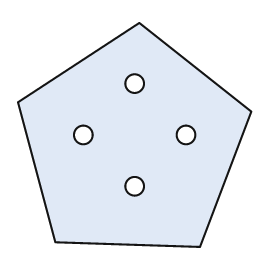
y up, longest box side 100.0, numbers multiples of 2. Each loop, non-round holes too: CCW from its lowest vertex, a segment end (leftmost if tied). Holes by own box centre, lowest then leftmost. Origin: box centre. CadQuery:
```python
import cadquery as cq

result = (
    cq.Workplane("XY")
    .moveTo(28.0, -48.0)
    .lineTo(50.0, 10.0)
    .lineTo(2.0, 48.0)
    .lineTo(-50.0, 14.0)
    .lineTo(-34.0, -46.0)
    .close()
    .moveTo(0.0, -22.0)
    .circle(4.0)
    .moveTo(-22.0, 0.0)
    .circle(4.0)
    .moveTo(22.0, 0.0)
    .circle(4.0)
    .moveTo(0.0, 22.0)
    .circle(4.0)
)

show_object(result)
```